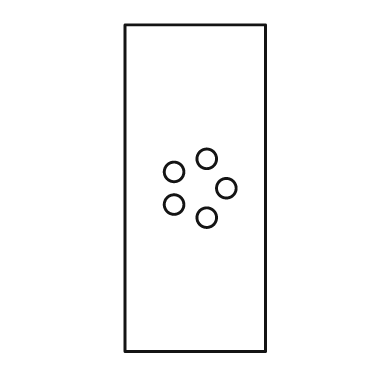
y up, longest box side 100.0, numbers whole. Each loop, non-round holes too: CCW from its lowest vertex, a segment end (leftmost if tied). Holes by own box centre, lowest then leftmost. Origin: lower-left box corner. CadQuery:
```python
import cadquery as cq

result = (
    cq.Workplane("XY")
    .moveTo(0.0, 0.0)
    .lineTo(43.0, 0.0)
    .lineTo(43.0, 100.0)
    .lineTo(0.0, 100.0)
    .close()
    .moveTo(25.0, 41.0)
    .circle(3.0)
    .moveTo(15.0, 45.0)
    .circle(3.0)
    .moveTo(31.0, 50.0)
    .circle(3.0)
    .moveTo(15.0, 55.0)
    .circle(3.0)
    .moveTo(25.0, 59.0)
    .circle(3.0)
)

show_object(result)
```